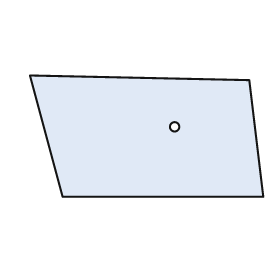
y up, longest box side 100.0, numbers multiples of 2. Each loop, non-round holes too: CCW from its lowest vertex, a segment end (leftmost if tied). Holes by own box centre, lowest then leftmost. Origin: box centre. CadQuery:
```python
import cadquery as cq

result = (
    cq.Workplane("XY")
    .moveTo(-36.0, -26.0)
    .lineTo(50.0, -26.0)
    .lineTo(44.0, 24.0)
    .lineTo(-50.0, 26.0)
    .close()
    .moveTo(12.0, 4.0)
    .circle(2.0)
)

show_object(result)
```